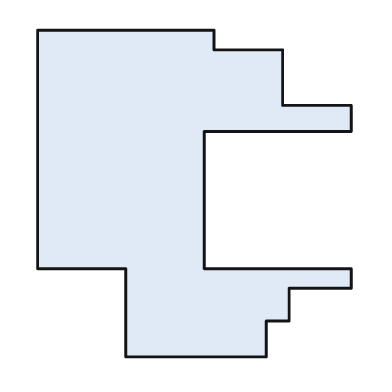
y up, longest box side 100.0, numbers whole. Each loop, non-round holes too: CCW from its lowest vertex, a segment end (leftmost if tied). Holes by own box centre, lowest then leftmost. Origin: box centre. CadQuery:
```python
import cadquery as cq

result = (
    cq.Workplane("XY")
    .moveTo(-21.0, -50.0)
    .lineTo(22.0, -50.0)
    .lineTo(22.0, -39.0)
    .lineTo(29.0, -39.0)
    .lineTo(29.0, -29.0)
    .lineTo(48.0, -29.0)
    .lineTo(48.0, -23.0)
    .lineTo(3.0, -23.0)
    .lineTo(3.0, 19.0)
    .lineTo(48.0, 19.0)
    .lineTo(48.0, 27.0)
    .lineTo(27.0, 27.0)
    .lineTo(27.0, 44.0)
    .lineTo(6.0, 44.0)
    .lineTo(6.0, 50.0)
    .lineTo(-48.0, 50.0)
    .lineTo(-48.0, -23.0)
    .lineTo(-21.0, -23.0)
    .close()
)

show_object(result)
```